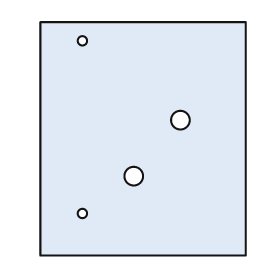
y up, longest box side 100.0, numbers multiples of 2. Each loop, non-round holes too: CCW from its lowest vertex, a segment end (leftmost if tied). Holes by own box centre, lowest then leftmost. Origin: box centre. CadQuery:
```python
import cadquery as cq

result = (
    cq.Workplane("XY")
    .moveTo(-44.0, -50.0)
    .lineTo(44.0, -50.0)
    .lineTo(44.0, 50.0)
    .lineTo(-44.0, 50.0)
    .close()
    .moveTo(-26.0, -32.0)
    .circle(2.0)
    .moveTo(-4.0, -16.0)
    .circle(4.0)
    .moveTo(16.0, 8.0)
    .circle(4.0)
    .moveTo(-26.0, 42.0)
    .circle(2.0)
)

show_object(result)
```